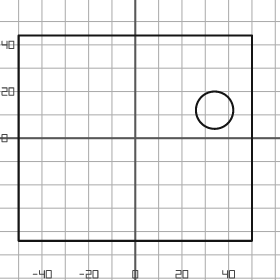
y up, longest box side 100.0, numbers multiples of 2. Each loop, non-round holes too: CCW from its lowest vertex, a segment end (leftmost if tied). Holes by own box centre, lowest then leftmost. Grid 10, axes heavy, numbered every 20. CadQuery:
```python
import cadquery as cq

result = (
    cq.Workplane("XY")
    .moveTo(-50.0, -44.0)
    .lineTo(50.0, -44.0)
    .lineTo(50.0, 44.0)
    .lineTo(-50.0, 44.0)
    .close()
    .moveTo(34.0, 12.0)
    .circle(8.0)
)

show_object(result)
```